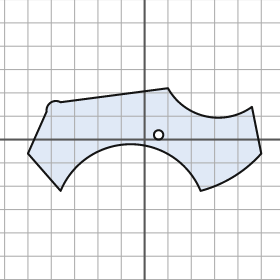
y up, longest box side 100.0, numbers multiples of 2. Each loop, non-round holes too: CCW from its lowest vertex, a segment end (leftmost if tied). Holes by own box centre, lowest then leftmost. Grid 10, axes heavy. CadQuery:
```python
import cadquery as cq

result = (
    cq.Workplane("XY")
    .moveTo(-36.0, -22.0)
    .threePointArc((-6.0, -2.0), (24.0, -22.0))
    .threePointArc((38.0, -16.0), (50.0, -6.0))
    .lineTo(46.0, 14.0)
    .threePointArc((26.0, 10.0), (10.0, 22.0))
    .lineTo(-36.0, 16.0)
    .threePointArc((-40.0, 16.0), (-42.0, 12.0))
    .lineTo(-50.0, -6.0)
    .close()
    .moveTo(6.0, 2.0)
    .circle(2.0)
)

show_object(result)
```